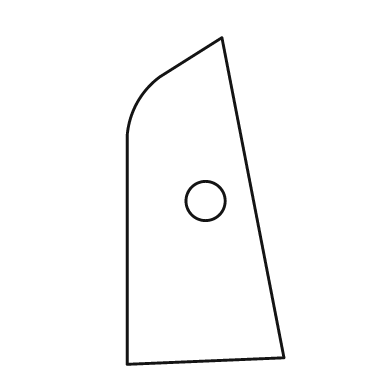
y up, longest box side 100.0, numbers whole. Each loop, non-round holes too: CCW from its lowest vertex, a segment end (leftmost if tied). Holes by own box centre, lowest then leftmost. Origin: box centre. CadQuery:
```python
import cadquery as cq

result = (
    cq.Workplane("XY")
    .moveTo(-24.0, -50.0)
    .lineTo(24.0, -48.0)
    .lineTo(5.0, 50.0)
    .lineTo(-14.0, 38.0)
    .threePointArc((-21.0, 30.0), (-24.0, 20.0))
    .close()
    .moveTo(0.0, 0.0)
    .circle(6.0)
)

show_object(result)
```